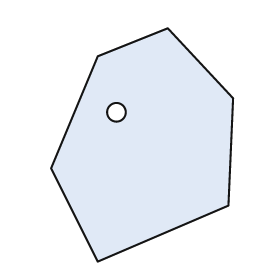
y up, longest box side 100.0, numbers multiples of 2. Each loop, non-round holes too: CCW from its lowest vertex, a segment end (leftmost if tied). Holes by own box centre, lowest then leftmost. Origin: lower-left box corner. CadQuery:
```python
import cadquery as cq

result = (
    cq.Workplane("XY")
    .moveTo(20.0, 0.0)
    .lineTo(76.0, 24.0)
    .lineTo(78.0, 70.0)
    .lineTo(50.0, 100.0)
    .lineTo(20.0, 88.0)
    .lineTo(0.0, 40.0)
    .close()
    .moveTo(28.0, 64.0)
    .circle(4.0)
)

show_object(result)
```